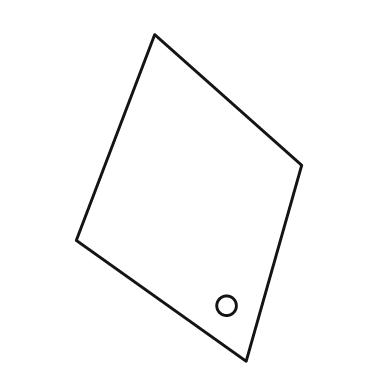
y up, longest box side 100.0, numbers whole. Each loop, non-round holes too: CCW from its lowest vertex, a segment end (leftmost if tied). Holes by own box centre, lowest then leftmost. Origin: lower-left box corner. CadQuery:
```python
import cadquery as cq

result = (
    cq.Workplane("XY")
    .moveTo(52.0, 0.0)
    .lineTo(69.0, 60.0)
    .lineTo(24.0, 100.0)
    .lineTo(0.0, 37.0)
    .close()
    .moveTo(46.0, 17.0)
    .circle(3.0)
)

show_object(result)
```